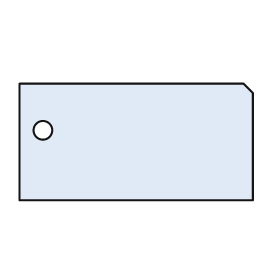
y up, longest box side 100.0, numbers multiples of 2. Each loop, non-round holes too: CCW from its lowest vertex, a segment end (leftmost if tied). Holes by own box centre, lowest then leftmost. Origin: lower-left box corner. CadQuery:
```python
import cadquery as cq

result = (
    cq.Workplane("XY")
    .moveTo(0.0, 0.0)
    .lineTo(100.0, 0.0)
    .lineTo(100.0, 46.0)
    .lineTo(96.0, 50.0)
    .lineTo(0.0, 50.0)
    .close()
    .moveTo(10.0, 30.0)
    .circle(4.0)
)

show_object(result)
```